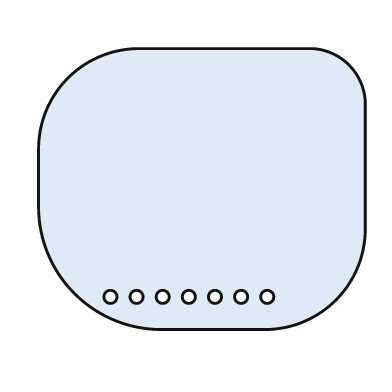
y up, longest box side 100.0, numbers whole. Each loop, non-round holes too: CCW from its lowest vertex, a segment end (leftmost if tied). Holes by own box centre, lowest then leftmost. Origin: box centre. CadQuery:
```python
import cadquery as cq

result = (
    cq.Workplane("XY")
    .moveTo(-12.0, -43.0)
    .lineTo(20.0, -43.0)
    .threePointArc((41.0, -34.0), (50.0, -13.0))
    .lineTo(50.0, 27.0)
    .threePointArc((45.0, 38.0), (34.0, 43.0))
    .lineTo(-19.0, 43.0)
    .threePointArc((-41.0, 34.0), (-50.0, 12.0))
    .lineTo(-50.0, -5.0)
    .threePointArc((-39.0, -32.0), (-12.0, -43.0))
    .close()
    .moveTo(-28.0, -33.0)
    .circle(2.0)
    .moveTo(-20.0, -33.0)
    .circle(2.0)
    .moveTo(-12.0, -33.0)
    .circle(2.0)
    .moveTo(-4.0, -33.0)
    .circle(2.0)
    .moveTo(4.0, -33.0)
    .circle(2.0)
    .moveTo(12.0, -33.0)
    .circle(2.0)
    .moveTo(20.0, -33.0)
    .circle(2.0)
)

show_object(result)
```